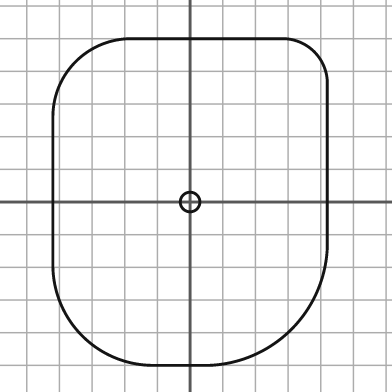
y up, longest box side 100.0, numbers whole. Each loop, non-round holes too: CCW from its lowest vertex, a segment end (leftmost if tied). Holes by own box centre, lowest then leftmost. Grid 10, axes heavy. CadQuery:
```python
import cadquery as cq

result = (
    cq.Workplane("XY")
    .moveTo(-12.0, -50.0)
    .lineTo(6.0, -50.0)
    .threePointArc((31.0, -39.0), (42.0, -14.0))
    .lineTo(42.0, 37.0)
    .threePointArc((38.0, 46.0), (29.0, 50.0))
    .lineTo(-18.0, 50.0)
    .threePointArc((-35.0, 43.0), (-42.0, 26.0))
    .lineTo(-42.0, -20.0)
    .threePointArc((-33.0, -41.0), (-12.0, -50.0))
    .close()
    .moveTo(0.0, 0.0)
    .circle(3.0)
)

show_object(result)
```